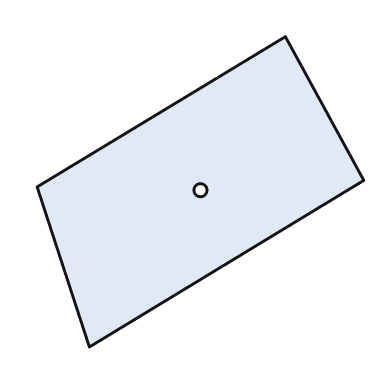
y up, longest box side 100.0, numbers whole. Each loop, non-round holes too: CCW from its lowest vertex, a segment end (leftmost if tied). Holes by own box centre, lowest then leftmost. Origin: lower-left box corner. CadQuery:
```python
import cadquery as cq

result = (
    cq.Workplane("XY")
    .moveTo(16.0, 0.0)
    .lineTo(100.0, 51.0)
    .lineTo(76.0, 95.0)
    .lineTo(0.0, 49.0)
    .close()
    .moveTo(50.0, 48.0)
    .circle(2.0)
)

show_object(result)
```